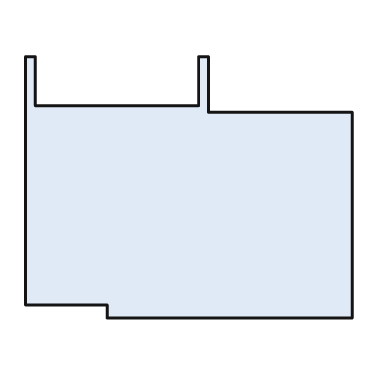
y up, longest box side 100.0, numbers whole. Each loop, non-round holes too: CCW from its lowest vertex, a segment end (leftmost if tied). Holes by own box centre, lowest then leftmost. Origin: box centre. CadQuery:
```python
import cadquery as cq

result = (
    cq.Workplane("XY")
    .moveTo(-25.0, -40.0)
    .lineTo(50.0, -40.0)
    .lineTo(50.0, 23.0)
    .lineTo(6.0, 23.0)
    .lineTo(6.0, 40.0)
    .lineTo(3.0, 40.0)
    .lineTo(3.0, 25.0)
    .lineTo(-47.0, 25.0)
    .lineTo(-47.0, 40.0)
    .lineTo(-50.0, 40.0)
    .lineTo(-50.0, -36.0)
    .lineTo(-25.0, -36.0)
    .close()
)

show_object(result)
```